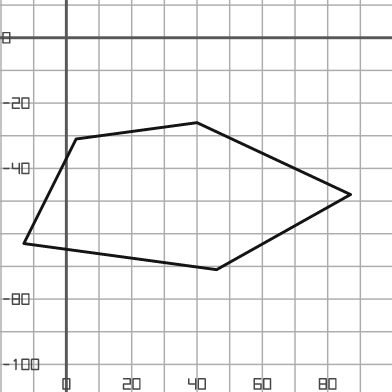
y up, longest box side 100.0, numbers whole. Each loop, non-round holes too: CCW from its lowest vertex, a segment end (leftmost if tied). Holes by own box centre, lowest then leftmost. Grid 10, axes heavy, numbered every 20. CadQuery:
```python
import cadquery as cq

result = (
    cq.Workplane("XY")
    .moveTo(46.0, -71.0)
    .lineTo(87.0, -48.0)
    .lineTo(40.0, -26.0)
    .lineTo(3.0, -31.0)
    .lineTo(-13.0, -63.0)
    .close()
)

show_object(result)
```